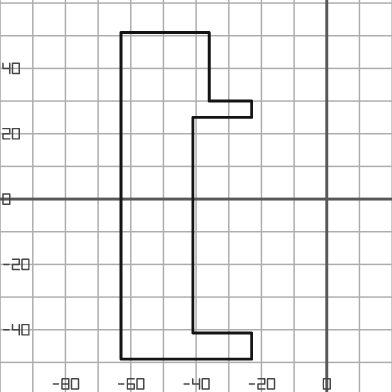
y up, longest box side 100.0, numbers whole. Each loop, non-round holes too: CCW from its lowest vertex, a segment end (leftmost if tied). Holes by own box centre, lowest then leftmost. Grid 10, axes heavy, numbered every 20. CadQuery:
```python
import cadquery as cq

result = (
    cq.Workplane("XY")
    .moveTo(-63.0, -49.0)
    .lineTo(-23.0, -49.0)
    .lineTo(-23.0, -41.0)
    .lineTo(-41.0, -41.0)
    .lineTo(-41.0, 25.0)
    .lineTo(-23.0, 25.0)
    .lineTo(-23.0, 30.0)
    .lineTo(-36.0, 30.0)
    .lineTo(-36.0, 51.0)
    .lineTo(-63.0, 51.0)
    .close()
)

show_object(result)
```